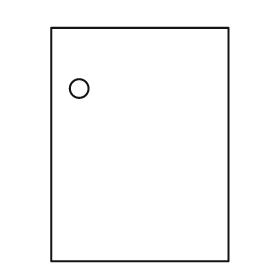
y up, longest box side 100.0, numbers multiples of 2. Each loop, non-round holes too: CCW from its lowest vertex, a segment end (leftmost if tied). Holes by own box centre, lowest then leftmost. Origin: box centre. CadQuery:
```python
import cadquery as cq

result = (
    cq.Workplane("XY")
    .moveTo(-38.0, -50.0)
    .lineTo(38.0, -50.0)
    .lineTo(38.0, 50.0)
    .lineTo(-38.0, 50.0)
    .close()
    .moveTo(-26.0, 24.0)
    .circle(4.0)
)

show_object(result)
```